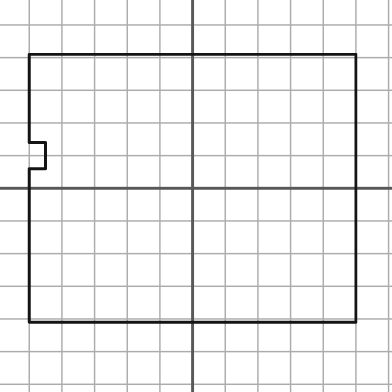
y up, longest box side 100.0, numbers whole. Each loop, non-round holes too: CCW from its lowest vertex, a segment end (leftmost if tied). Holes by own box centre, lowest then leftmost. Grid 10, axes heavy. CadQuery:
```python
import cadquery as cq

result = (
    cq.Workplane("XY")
    .moveTo(-50.0, -41.0)
    .lineTo(50.0, -41.0)
    .lineTo(50.0, 41.0)
    .lineTo(-50.0, 41.0)
    .lineTo(-50.0, 14.0)
    .lineTo(-45.0, 14.0)
    .lineTo(-45.0, 6.0)
    .lineTo(-50.0, 6.0)
    .close()
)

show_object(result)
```